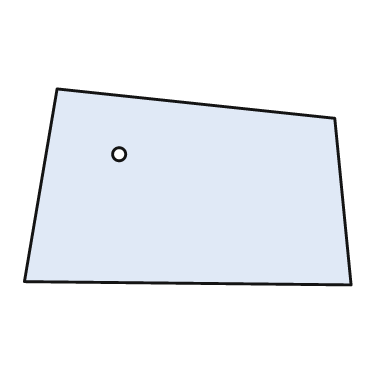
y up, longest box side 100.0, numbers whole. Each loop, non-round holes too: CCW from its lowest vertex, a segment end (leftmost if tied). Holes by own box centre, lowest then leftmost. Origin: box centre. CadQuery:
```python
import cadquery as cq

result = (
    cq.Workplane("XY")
    .moveTo(50.0, -30.0)
    .lineTo(45.0, 21.0)
    .lineTo(-40.0, 30.0)
    .lineTo(-50.0, -29.0)
    .close()
    .moveTo(-21.0, 10.0)
    .circle(2.0)
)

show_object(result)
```